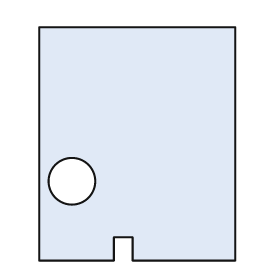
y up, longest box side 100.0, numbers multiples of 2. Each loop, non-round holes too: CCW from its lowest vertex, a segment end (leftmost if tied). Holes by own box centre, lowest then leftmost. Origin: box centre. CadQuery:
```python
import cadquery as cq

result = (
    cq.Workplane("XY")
    .moveTo(-42.0, -50.0)
    .lineTo(-10.0, -50.0)
    .lineTo(-10.0, -40.0)
    .lineTo(-2.0, -40.0)
    .lineTo(-2.0, -50.0)
    .lineTo(42.0, -50.0)
    .lineTo(42.0, 50.0)
    .lineTo(-42.0, 50.0)
    .close()
    .moveTo(-28.0, -16.0)
    .circle(10.0)
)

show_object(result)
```